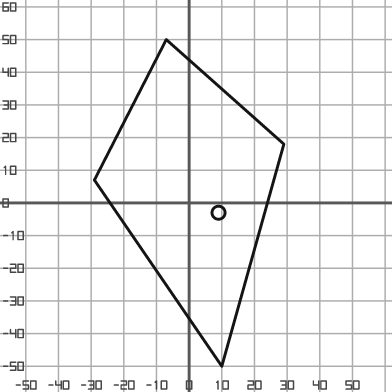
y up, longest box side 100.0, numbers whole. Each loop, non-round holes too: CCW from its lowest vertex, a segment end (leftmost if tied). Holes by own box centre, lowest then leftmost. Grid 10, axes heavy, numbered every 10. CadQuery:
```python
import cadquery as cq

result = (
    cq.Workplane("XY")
    .moveTo(10.0, -50.0)
    .lineTo(29.0, 18.0)
    .lineTo(-7.0, 50.0)
    .lineTo(-29.0, 7.0)
    .close()
    .moveTo(9.0, -3.0)
    .circle(2.0)
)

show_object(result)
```